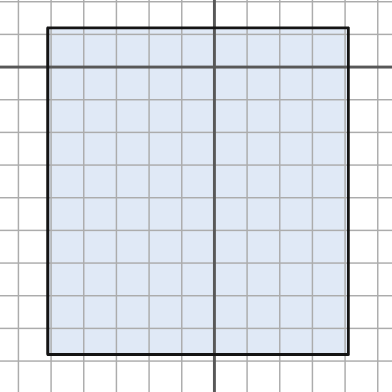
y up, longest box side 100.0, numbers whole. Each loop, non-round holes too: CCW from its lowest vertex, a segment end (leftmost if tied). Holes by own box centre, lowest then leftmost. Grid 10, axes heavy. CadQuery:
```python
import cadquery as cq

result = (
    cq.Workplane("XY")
    .moveTo(-51.0, -88.0)
    .lineTo(41.0, -88.0)
    .lineTo(41.0, 12.0)
    .lineTo(-51.0, 12.0)
    .close()
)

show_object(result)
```